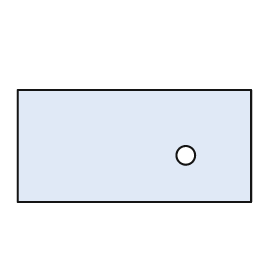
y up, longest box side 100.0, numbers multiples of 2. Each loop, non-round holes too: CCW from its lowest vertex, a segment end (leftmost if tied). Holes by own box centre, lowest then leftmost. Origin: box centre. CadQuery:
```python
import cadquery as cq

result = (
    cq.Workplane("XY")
    .moveTo(-50.0, -24.0)
    .lineTo(50.0, -24.0)
    .lineTo(50.0, 24.0)
    .lineTo(-50.0, 24.0)
    .close()
    .moveTo(22.0, -4.0)
    .circle(4.0)
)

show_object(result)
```